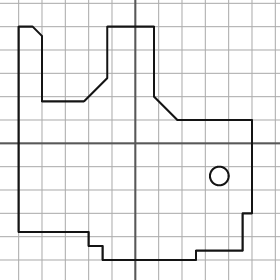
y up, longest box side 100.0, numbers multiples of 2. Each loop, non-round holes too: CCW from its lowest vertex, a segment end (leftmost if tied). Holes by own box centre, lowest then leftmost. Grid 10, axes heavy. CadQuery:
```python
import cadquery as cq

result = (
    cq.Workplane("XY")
    .moveTo(-14.0, -50.0)
    .lineTo(26.0, -50.0)
    .lineTo(26.0, -46.0)
    .lineTo(46.0, -46.0)
    .lineTo(46.0, -30.0)
    .lineTo(50.0, -30.0)
    .lineTo(50.0, 10.0)
    .lineTo(18.0, 10.0)
    .lineTo(8.0, 20.0)
    .lineTo(8.0, 50.0)
    .lineTo(-12.0, 50.0)
    .lineTo(-12.0, 28.0)
    .lineTo(-22.0, 18.0)
    .lineTo(-40.0, 18.0)
    .lineTo(-40.0, 46.0)
    .lineTo(-44.0, 50.0)
    .lineTo(-50.0, 50.0)
    .lineTo(-50.0, -38.0)
    .lineTo(-20.0, -38.0)
    .lineTo(-20.0, -44.0)
    .lineTo(-14.0, -44.0)
    .close()
    .moveTo(36.0, -14.0)
    .circle(4.0)
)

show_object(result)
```